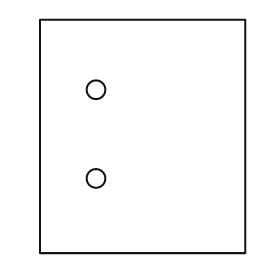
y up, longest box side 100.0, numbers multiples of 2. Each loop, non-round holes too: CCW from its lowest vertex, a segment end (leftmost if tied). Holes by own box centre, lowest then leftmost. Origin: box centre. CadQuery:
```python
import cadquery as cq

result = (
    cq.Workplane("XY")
    .moveTo(-44.0, -50.0)
    .lineTo(44.0, -50.0)
    .lineTo(44.0, 50.0)
    .lineTo(-44.0, 50.0)
    .close()
    .moveTo(-20.0, -18.0)
    .circle(4.0)
    .moveTo(-20.0, 20.0)
    .circle(4.0)
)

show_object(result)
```